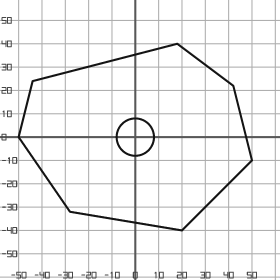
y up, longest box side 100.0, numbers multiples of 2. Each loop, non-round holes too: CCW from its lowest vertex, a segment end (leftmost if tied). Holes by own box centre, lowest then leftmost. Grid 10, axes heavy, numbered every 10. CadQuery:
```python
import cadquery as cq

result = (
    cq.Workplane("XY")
    .moveTo(20.0, -40.0)
    .lineTo(50.0, -10.0)
    .lineTo(42.0, 22.0)
    .lineTo(18.0, 40.0)
    .lineTo(-44.0, 24.0)
    .lineTo(-50.0, 0.0)
    .lineTo(-28.0, -32.0)
    .close()
    .moveTo(0.0, 0.0)
    .circle(8.0)
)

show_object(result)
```